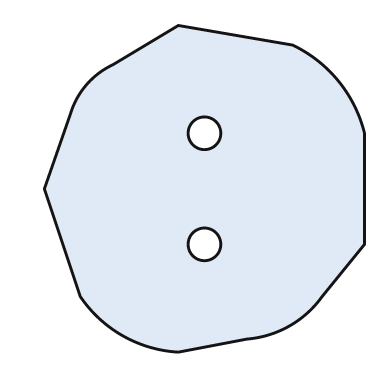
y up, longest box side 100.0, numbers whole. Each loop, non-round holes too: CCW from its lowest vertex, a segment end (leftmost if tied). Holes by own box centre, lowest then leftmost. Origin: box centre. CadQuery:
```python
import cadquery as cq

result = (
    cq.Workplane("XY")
    .moveTo(-8.0, -50.0)
    .lineTo(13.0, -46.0)
    .threePointArc((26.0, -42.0), (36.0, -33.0))
    .lineTo(49.0, -17.0)
    .lineTo(49.0, 17.0)
    .threePointArc((41.0, 33.0), (27.0, 44.0))
    .lineTo(-8.0, 50.0)
    .lineTo(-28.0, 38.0)
    .threePointArc((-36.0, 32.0), (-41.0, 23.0))
    .lineTo(-49.0, 0.0)
    .lineTo(-38.0, -33.0)
    .threePointArc((-25.0, -45.0), (-8.0, -50.0))
    .close()
    .moveTo(0.0, -17.0)
    .circle(5.0)
    .moveTo(0.0, 17.0)
    .circle(5.0)
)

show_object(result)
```